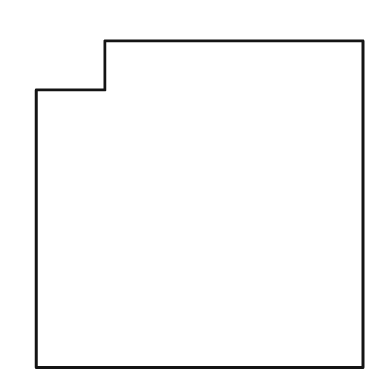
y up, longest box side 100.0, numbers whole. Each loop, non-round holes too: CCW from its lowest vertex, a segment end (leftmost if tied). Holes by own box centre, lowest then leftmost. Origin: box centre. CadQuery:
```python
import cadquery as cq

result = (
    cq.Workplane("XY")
    .moveTo(-50.0, -50.0)
    .lineTo(50.0, -50.0)
    .lineTo(50.0, 50.0)
    .lineTo(-29.0, 50.0)
    .lineTo(-29.0, 35.0)
    .lineTo(-50.0, 35.0)
    .close()
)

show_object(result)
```